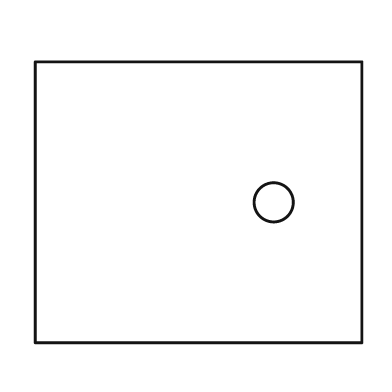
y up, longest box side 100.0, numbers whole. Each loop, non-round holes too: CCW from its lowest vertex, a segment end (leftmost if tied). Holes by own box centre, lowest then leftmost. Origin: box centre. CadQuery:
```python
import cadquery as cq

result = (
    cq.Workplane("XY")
    .moveTo(-50.0, -43.0)
    .lineTo(50.0, -43.0)
    .lineTo(50.0, 43.0)
    .lineTo(-50.0, 43.0)
    .close()
    .moveTo(23.0, 0.0)
    .circle(6.0)
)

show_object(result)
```